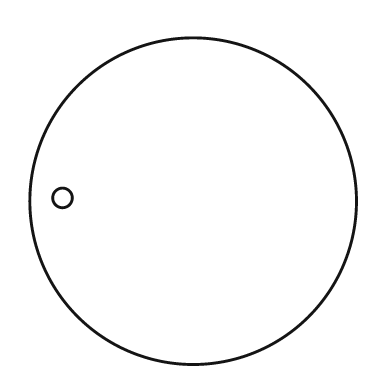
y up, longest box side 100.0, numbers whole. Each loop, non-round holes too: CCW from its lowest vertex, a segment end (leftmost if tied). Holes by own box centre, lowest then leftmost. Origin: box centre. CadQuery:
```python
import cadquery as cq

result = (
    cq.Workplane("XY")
    .moveTo(0.0, 0.0)
    .circle(50.0)
    .moveTo(-40.0, 1.0)
    .circle(3.0)
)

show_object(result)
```